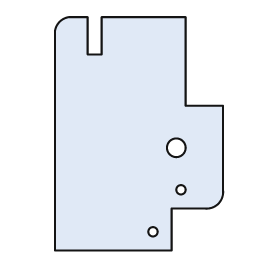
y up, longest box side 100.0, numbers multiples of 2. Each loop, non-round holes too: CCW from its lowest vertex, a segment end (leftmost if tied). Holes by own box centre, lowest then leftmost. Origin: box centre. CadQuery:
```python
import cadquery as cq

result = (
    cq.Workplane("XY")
    .moveTo(-36.0, -50.0)
    .lineTo(14.0, -50.0)
    .lineTo(14.0, -32.0)
    .lineTo(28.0, -32.0)
    .threePointArc((34.0, -30.0), (36.0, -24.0))
    .lineTo(36.0, 12.0)
    .lineTo(20.0, 12.0)
    .lineTo(20.0, 50.0)
    .lineTo(-16.0, 50.0)
    .lineTo(-16.0, 34.0)
    .lineTo(-22.0, 34.0)
    .lineTo(-22.0, 50.0)
    .lineTo(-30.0, 50.0)
    .threePointArc((-34.0, 48.0), (-36.0, 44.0))
    .close()
    .moveTo(6.0, -42.0)
    .circle(2.0)
    .moveTo(18.0, -24.0)
    .circle(2.0)
    .moveTo(16.0, -6.0)
    .circle(4.0)
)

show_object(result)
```